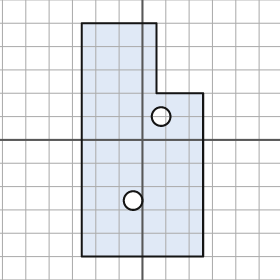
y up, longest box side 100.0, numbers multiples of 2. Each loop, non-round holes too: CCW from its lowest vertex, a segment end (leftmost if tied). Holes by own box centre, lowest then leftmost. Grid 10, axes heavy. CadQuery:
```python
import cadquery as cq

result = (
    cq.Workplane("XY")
    .moveTo(-26.0, -50.0)
    .lineTo(26.0, -50.0)
    .lineTo(26.0, 20.0)
    .lineTo(6.0, 20.0)
    .lineTo(6.0, 50.0)
    .lineTo(-26.0, 50.0)
    .close()
    .moveTo(-4.0, -26.0)
    .circle(4.0)
    .moveTo(8.0, 10.0)
    .circle(4.0)
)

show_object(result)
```